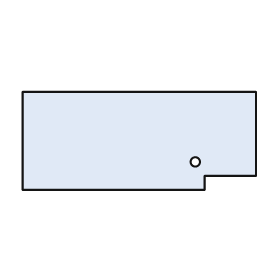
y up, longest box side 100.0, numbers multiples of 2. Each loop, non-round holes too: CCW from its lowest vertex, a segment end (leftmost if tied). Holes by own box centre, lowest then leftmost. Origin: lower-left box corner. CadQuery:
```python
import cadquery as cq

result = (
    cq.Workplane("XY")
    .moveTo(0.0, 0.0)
    .lineTo(78.0, 0.0)
    .lineTo(78.0, 6.0)
    .lineTo(100.0, 6.0)
    .lineTo(100.0, 42.0)
    .lineTo(0.0, 42.0)
    .close()
    .moveTo(74.0, 12.0)
    .circle(2.0)
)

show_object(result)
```